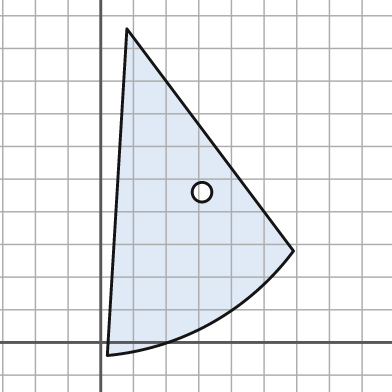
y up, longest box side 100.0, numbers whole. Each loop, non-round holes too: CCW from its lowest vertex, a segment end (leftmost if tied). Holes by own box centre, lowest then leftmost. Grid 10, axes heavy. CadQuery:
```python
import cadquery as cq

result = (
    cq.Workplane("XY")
    .moveTo(2.0, -4.0)
    .threePointArc((34.0, 6.0), (59.0, 28.0))
    .lineTo(8.0, 96.0)
    .close()
    .moveTo(31.0, 46.0)
    .circle(3.0)
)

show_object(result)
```